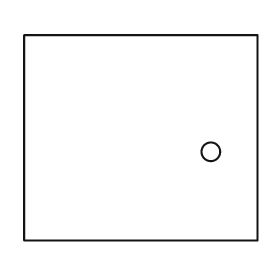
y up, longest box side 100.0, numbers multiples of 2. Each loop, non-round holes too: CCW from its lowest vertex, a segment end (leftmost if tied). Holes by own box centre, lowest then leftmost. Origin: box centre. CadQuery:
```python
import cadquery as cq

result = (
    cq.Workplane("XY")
    .moveTo(-50.0, -44.0)
    .lineTo(50.0, -44.0)
    .lineTo(50.0, 44.0)
    .lineTo(-50.0, 44.0)
    .close()
    .moveTo(30.0, -6.0)
    .circle(4.0)
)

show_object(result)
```